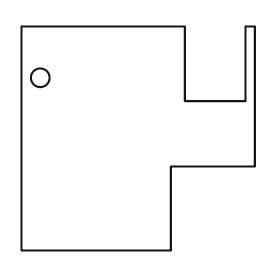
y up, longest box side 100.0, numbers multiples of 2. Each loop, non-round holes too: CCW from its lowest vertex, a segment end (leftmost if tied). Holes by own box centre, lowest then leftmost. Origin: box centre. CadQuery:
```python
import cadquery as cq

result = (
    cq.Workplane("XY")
    .moveTo(-50.0, -48.0)
    .lineTo(14.0, -48.0)
    .lineTo(14.0, -12.0)
    .lineTo(50.0, -12.0)
    .lineTo(50.0, 48.0)
    .lineTo(46.0, 48.0)
    .lineTo(46.0, 16.0)
    .lineTo(20.0, 16.0)
    .lineTo(20.0, 48.0)
    .lineTo(-50.0, 48.0)
    .close()
    .moveTo(-42.0, 26.0)
    .circle(4.0)
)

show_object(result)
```